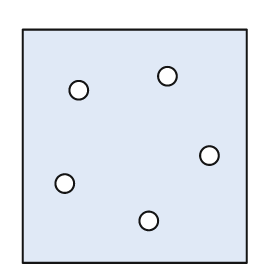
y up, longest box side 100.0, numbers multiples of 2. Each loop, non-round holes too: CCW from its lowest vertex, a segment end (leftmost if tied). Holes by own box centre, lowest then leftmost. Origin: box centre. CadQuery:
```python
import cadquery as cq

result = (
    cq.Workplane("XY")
    .moveTo(-48.0, -50.0)
    .lineTo(48.0, -50.0)
    .lineTo(48.0, 50.0)
    .lineTo(-48.0, 50.0)
    .close()
    .moveTo(6.0, -32.0)
    .circle(4.0)
    .moveTo(-30.0, -16.0)
    .circle(4.0)
    .moveTo(32.0, -4.0)
    .circle(4.0)
    .moveTo(-24.0, 24.0)
    .circle(4.0)
    .moveTo(14.0, 30.0)
    .circle(4.0)
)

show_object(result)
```